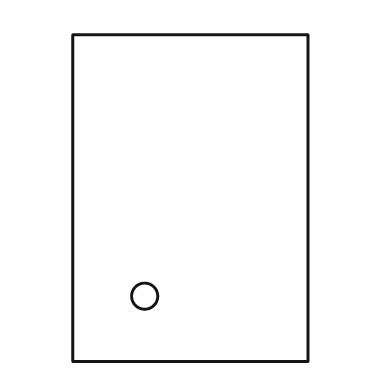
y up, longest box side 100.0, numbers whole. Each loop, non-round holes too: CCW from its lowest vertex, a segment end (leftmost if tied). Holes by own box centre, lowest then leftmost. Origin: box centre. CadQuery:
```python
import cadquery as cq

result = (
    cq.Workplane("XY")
    .moveTo(-36.0, -50.0)
    .lineTo(36.0, -50.0)
    .lineTo(36.0, 50.0)
    .lineTo(-36.0, 50.0)
    .close()
    .moveTo(-14.0, -30.0)
    .circle(4.0)
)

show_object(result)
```